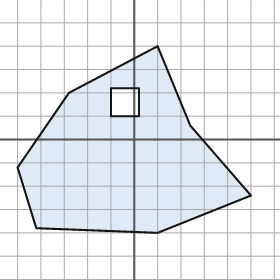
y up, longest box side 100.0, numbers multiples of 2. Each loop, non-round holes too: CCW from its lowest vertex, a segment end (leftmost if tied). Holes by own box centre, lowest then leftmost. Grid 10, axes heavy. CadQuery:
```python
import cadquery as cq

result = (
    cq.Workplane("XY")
    .moveTo(10.0, -40.0)
    .lineTo(50.0, -24.0)
    .lineTo(24.0, 6.0)
    .lineTo(10.0, 40.0)
    .lineTo(-28.0, 20.0)
    .lineTo(-50.0, -12.0)
    .lineTo(-42.0, -38.0)
    .close()
    .moveTo(-10.0, 10.0)
    .lineTo(2.0, 10.0)
    .lineTo(2.0, 22.0)
    .lineTo(-10.0, 22.0)
    .close()
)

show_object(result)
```